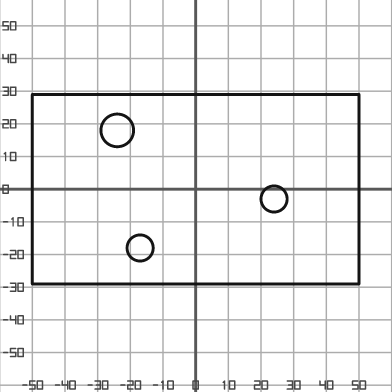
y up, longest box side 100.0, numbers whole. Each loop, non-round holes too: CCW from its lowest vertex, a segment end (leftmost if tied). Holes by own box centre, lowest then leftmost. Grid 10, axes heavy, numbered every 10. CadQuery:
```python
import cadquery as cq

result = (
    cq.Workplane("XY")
    .moveTo(-50.0, -29.0)
    .lineTo(50.0, -29.0)
    .lineTo(50.0, 29.0)
    .lineTo(-50.0, 29.0)
    .close()
    .moveTo(-17.0, -18.0)
    .circle(4.0)
    .moveTo(24.0, -3.0)
    .circle(4.0)
    .moveTo(-24.0, 18.0)
    .circle(5.0)
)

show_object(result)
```